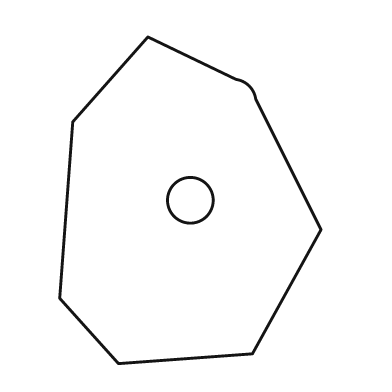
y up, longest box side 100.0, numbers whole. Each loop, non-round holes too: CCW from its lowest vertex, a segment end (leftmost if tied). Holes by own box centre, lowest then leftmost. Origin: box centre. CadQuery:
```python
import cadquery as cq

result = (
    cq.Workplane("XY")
    .moveTo(-22.0, -50.0)
    .lineTo(19.0, -47.0)
    .lineTo(40.0, -9.0)
    .lineTo(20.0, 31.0)
    .threePointArc((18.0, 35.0), (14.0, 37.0))
    .lineTo(-13.0, 50.0)
    .lineTo(-36.0, 24.0)
    .lineTo(-40.0, -30.0)
    .close()
    .moveTo(0.0, 0.0)
    .circle(7.0)
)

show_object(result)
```